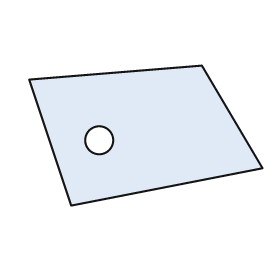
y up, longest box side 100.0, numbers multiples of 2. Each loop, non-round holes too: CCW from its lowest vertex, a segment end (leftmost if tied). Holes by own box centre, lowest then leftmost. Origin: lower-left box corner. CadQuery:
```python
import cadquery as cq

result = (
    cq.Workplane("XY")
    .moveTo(18.0, 0.0)
    .lineTo(100.0, 16.0)
    .lineTo(74.0, 60.0)
    .lineTo(0.0, 54.0)
    .close()
    .moveTo(30.0, 28.0)
    .circle(6.0)
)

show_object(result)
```